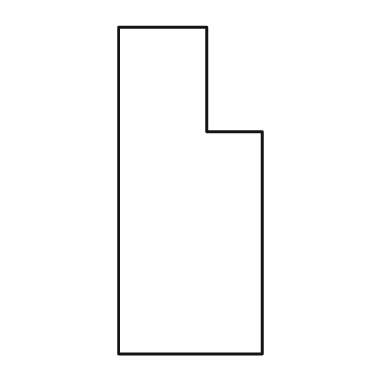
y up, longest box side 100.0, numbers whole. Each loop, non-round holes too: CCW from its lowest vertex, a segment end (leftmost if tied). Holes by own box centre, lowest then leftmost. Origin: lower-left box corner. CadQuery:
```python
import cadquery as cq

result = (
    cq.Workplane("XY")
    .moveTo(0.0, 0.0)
    .lineTo(44.0, 0.0)
    .lineTo(44.0, 68.0)
    .lineTo(27.0, 68.0)
    .lineTo(27.0, 100.0)
    .lineTo(0.0, 100.0)
    .close()
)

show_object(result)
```